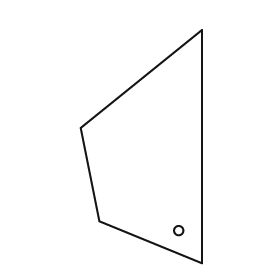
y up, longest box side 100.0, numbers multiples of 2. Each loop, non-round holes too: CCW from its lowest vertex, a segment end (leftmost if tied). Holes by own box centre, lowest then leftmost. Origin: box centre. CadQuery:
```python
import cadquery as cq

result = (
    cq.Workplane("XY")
    .moveTo(26.0, -50.0)
    .lineTo(26.0, 50.0)
    .lineTo(-26.0, 8.0)
    .lineTo(-18.0, -32.0)
    .close()
    .moveTo(16.0, -36.0)
    .circle(2.0)
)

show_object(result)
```